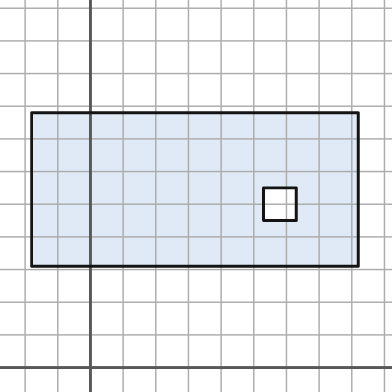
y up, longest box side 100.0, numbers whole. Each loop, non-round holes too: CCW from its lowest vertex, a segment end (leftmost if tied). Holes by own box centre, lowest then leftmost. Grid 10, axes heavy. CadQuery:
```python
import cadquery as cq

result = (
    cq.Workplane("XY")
    .moveTo(-18.0, 31.0)
    .lineTo(82.0, 31.0)
    .lineTo(82.0, 78.0)
    .lineTo(-18.0, 78.0)
    .close()
    .moveTo(53.0, 45.0)
    .lineTo(63.0, 45.0)
    .lineTo(63.0, 55.0)
    .lineTo(53.0, 55.0)
    .close()
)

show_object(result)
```